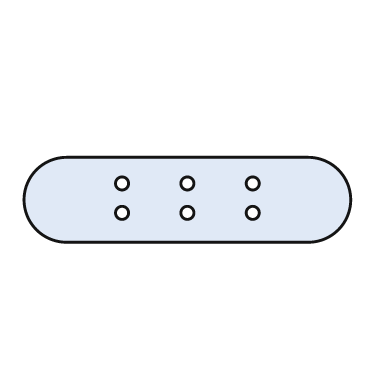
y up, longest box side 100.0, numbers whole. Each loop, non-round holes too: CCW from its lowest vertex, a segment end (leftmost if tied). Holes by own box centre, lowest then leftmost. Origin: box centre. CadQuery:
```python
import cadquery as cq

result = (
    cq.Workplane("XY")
    .moveTo(-37.0, -13.0)
    .lineTo(37.0, -13.0)
    .threePointArc((50.0, 0.0), (37.0, 13.0))
    .lineTo(-37.0, 13.0)
    .threePointArc((-50.0, 0.0), (-37.0, -13.0))
    .close()
    .moveTo(-20.0, -4.0)
    .circle(2.0)
    .moveTo(0.0, -4.0)
    .circle(2.0)
    .moveTo(20.0, -4.0)
    .circle(2.0)
    .moveTo(-20.0, 5.0)
    .circle(2.0)
    .moveTo(0.0, 5.0)
    .circle(2.0)
    .moveTo(20.0, 5.0)
    .circle(2.0)
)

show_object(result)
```